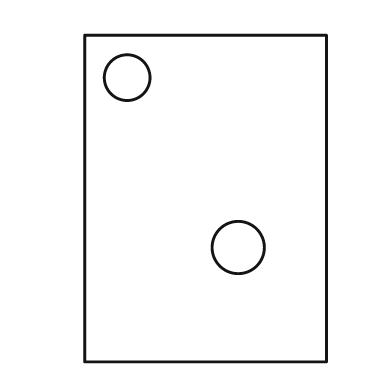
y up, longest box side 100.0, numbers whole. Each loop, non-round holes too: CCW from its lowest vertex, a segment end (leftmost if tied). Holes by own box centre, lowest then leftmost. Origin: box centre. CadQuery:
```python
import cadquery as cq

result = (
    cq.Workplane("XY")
    .moveTo(-37.0, -50.0)
    .lineTo(37.0, -50.0)
    .lineTo(37.0, 50.0)
    .lineTo(-37.0, 50.0)
    .close()
    .moveTo(10.0, -15.0)
    .circle(8.0)
    .moveTo(-24.0, 37.0)
    .circle(7.0)
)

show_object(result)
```